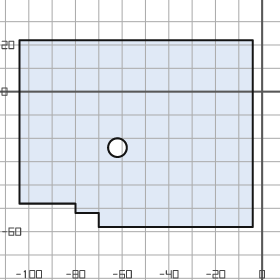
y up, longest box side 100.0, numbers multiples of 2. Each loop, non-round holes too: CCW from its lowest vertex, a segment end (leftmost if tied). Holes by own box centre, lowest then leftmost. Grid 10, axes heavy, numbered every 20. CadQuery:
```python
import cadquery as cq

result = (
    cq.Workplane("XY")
    .moveTo(-70.0, -58.0)
    .lineTo(-4.0, -58.0)
    .lineTo(-4.0, 22.0)
    .lineTo(-104.0, 22.0)
    .lineTo(-104.0, -48.0)
    .lineTo(-80.0, -48.0)
    .lineTo(-80.0, -52.0)
    .lineTo(-70.0, -52.0)
    .close()
    .moveTo(-62.0, -24.0)
    .circle(4.0)
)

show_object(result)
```